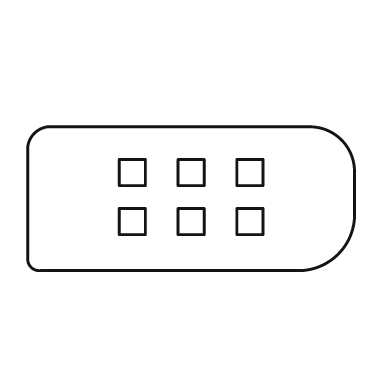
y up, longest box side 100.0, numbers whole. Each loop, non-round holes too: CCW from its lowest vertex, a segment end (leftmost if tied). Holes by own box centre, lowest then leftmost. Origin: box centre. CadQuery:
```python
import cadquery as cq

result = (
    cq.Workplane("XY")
    .moveTo(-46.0, -22.0)
    .lineTo(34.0, -22.0)
    .threePointArc((45.0, -17.0), (50.0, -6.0))
    .lineTo(50.0, 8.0)
    .threePointArc((46.0, 18.0), (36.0, 22.0))
    .lineTo(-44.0, 22.0)
    .threePointArc((-48.0, 20.0), (-50.0, 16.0))
    .lineTo(-50.0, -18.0)
    .threePointArc((-49.0, -21.0), (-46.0, -22.0))
    .close()
    .moveTo(-22.0, -11.0)
    .lineTo(-14.0, -11.0)
    .lineTo(-14.0, -3.0)
    .lineTo(-22.0, -3.0)
    .close()
    .moveTo(-4.0, -11.0)
    .lineTo(4.0, -11.0)
    .lineTo(4.0, -3.0)
    .lineTo(-4.0, -3.0)
    .close()
    .moveTo(14.0, -11.0)
    .lineTo(22.0, -11.0)
    .lineTo(22.0, -3.0)
    .lineTo(14.0, -3.0)
    .close()
    .moveTo(-22.0, 4.0)
    .lineTo(-14.0, 4.0)
    .lineTo(-14.0, 12.0)
    .lineTo(-22.0, 12.0)
    .close()
    .moveTo(-4.0, 4.0)
    .lineTo(4.0, 4.0)
    .lineTo(4.0, 12.0)
    .lineTo(-4.0, 12.0)
    .close()
    .moveTo(14.0, 4.0)
    .lineTo(22.0, 4.0)
    .lineTo(22.0, 12.0)
    .lineTo(14.0, 12.0)
    .close()
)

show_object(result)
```